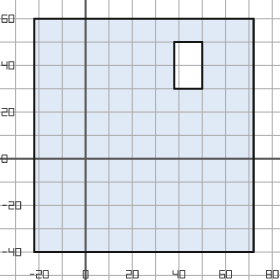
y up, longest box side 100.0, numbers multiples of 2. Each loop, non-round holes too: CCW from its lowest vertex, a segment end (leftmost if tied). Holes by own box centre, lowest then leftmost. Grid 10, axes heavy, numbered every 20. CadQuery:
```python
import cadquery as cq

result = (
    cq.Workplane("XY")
    .moveTo(-22.0, -40.0)
    .lineTo(72.0, -40.0)
    .lineTo(72.0, 60.0)
    .lineTo(-22.0, 60.0)
    .close()
    .moveTo(38.0, 30.0)
    .lineTo(50.0, 30.0)
    .lineTo(50.0, 50.0)
    .lineTo(38.0, 50.0)
    .close()
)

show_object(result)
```